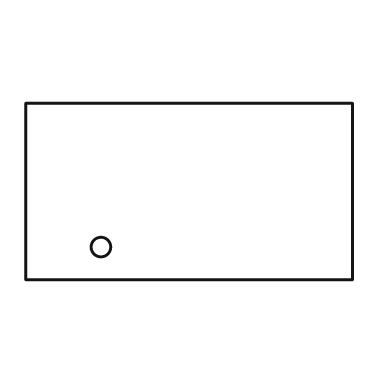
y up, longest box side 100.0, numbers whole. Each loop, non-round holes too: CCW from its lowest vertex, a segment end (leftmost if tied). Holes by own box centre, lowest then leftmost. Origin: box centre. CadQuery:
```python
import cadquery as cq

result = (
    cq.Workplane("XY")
    .moveTo(-50.0, -27.0)
    .lineTo(50.0, -27.0)
    .lineTo(50.0, 27.0)
    .lineTo(-50.0, 27.0)
    .close()
    .moveTo(-27.0, -17.0)
    .circle(3.0)
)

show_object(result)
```